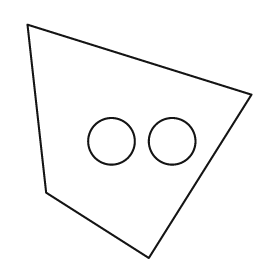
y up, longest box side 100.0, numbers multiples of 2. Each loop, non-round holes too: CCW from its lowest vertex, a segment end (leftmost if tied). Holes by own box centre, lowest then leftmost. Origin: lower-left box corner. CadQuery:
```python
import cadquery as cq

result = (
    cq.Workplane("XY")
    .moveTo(52.0, 0.0)
    .lineTo(96.0, 70.0)
    .lineTo(0.0, 100.0)
    .lineTo(8.0, 28.0)
    .close()
    .moveTo(36.0, 50.0)
    .circle(10.0)
    .moveTo(62.0, 50.0)
    .circle(10.0)
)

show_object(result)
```